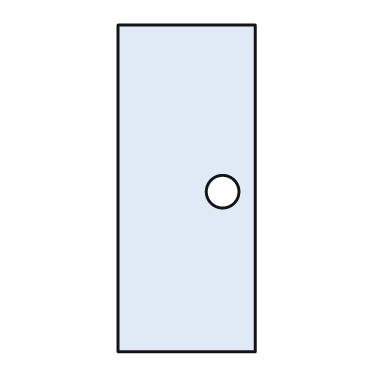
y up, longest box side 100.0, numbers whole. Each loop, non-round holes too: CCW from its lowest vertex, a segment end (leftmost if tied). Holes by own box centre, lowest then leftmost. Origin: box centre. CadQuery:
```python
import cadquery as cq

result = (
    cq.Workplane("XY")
    .moveTo(-21.0, -50.0)
    .lineTo(21.0, -50.0)
    .lineTo(21.0, 50.0)
    .lineTo(-21.0, 50.0)
    .close()
    .moveTo(11.0, -1.0)
    .circle(5.0)
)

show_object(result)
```